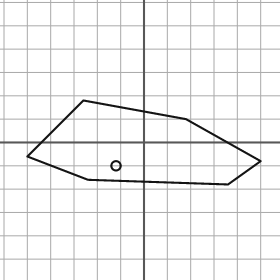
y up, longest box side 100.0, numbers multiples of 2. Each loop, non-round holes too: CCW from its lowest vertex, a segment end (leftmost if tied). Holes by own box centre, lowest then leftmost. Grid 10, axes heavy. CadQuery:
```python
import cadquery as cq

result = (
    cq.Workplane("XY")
    .moveTo(36.0, -18.0)
    .lineTo(50.0, -8.0)
    .lineTo(18.0, 10.0)
    .lineTo(-26.0, 18.0)
    .lineTo(-50.0, -6.0)
    .lineTo(-24.0, -16.0)
    .close()
    .moveTo(-12.0, -10.0)
    .circle(2.0)
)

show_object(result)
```